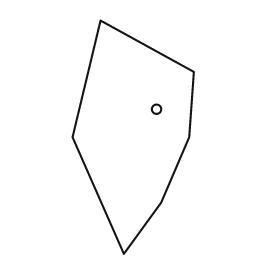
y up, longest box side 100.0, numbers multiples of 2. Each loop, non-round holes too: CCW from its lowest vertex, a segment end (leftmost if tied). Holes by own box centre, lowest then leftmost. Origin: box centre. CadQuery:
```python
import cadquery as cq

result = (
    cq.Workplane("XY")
    .moveTo(-4.0, -50.0)
    .lineTo(12.0, -28.0)
    .lineTo(24.0, 0.0)
    .lineTo(26.0, 28.0)
    .lineTo(-14.0, 50.0)
    .lineTo(-26.0, 0.0)
    .close()
    .moveTo(10.0, 12.0)
    .circle(2.0)
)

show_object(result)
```